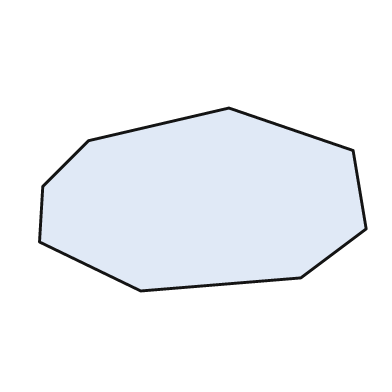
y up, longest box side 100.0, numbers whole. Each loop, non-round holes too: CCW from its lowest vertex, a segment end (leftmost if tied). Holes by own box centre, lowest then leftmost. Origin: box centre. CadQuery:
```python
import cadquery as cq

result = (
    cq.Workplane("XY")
    .moveTo(-19.0, -28.0)
    .lineTo(30.0, -24.0)
    .lineTo(50.0, -9.0)
    .lineTo(46.0, 15.0)
    .lineTo(8.0, 28.0)
    .lineTo(-35.0, 18.0)
    .lineTo(-49.0, 4.0)
    .lineTo(-50.0, -13.0)
    .close()
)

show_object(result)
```